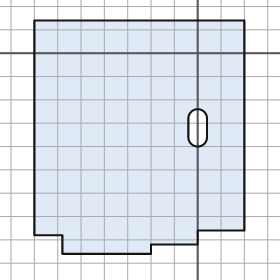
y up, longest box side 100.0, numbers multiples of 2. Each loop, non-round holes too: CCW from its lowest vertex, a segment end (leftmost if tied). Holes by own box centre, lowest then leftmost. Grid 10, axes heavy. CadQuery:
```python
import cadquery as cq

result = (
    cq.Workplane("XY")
    .moveTo(-58.0, -86.0)
    .lineTo(-20.0, -86.0)
    .lineTo(-20.0, -82.0)
    .lineTo(0.0, -82.0)
    .lineTo(0.0, -76.0)
    .lineTo(20.0, -76.0)
    .lineTo(20.0, 14.0)
    .lineTo(-70.0, 14.0)
    .lineTo(-70.0, -78.0)
    .lineTo(-58.0, -78.0)
    .close()
    .moveTo(-4.0, -36.0)
    .threePointArc((0.0, -40.0), (4.0, -36.0))
    .lineTo(4.0, -28.0)
    .threePointArc((0.0, -24.0), (-4.0, -28.0))
    .close()
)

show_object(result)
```